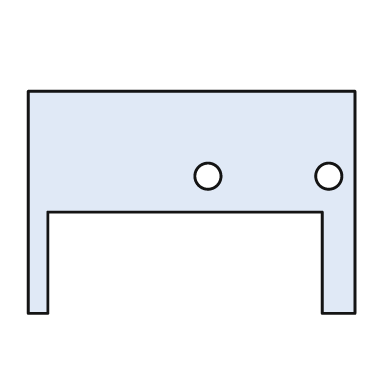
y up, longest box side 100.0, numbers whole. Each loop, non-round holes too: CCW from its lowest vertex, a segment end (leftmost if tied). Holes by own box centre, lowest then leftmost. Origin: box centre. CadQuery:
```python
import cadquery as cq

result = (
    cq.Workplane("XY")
    .moveTo(-50.0, -34.0)
    .lineTo(-44.0, -34.0)
    .lineTo(-44.0, -3.0)
    .lineTo(40.0, -3.0)
    .lineTo(40.0, -34.0)
    .lineTo(50.0, -34.0)
    .lineTo(50.0, 34.0)
    .lineTo(-50.0, 34.0)
    .close()
    .moveTo(5.0, 8.0)
    .circle(4.0)
    .moveTo(42.0, 8.0)
    .circle(4.0)
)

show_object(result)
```